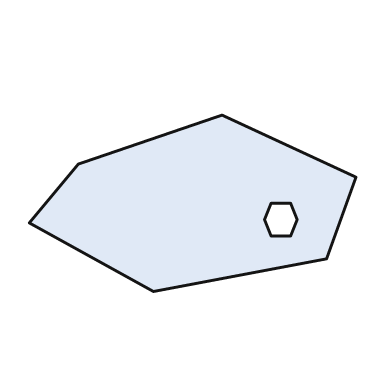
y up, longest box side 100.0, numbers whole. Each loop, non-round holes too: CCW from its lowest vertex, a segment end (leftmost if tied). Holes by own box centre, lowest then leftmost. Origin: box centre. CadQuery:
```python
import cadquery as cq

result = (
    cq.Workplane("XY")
    .moveTo(-12.0, -27.0)
    .lineTo(41.0, -17.0)
    .lineTo(50.0, 8.0)
    .lineTo(9.0, 27.0)
    .lineTo(-35.0, 12.0)
    .lineTo(-50.0, -6.0)
    .close()
    .moveTo(24.0, -10.0)
    .lineTo(30.0, -10.0)
    .lineTo(32.0, -5.0)
    .lineTo(30.0, 0.0)
    .lineTo(24.0, 0.0)
    .lineTo(22.0, -5.0)
    .close()
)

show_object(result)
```